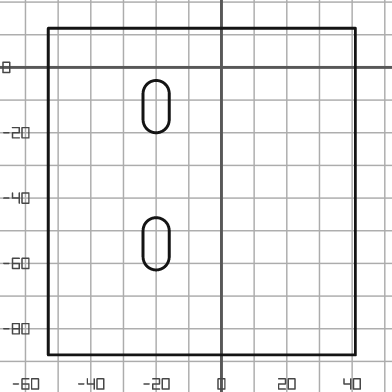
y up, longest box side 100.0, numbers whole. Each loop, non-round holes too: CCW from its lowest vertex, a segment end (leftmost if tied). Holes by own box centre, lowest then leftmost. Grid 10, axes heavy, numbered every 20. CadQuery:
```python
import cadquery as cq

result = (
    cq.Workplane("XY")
    .moveTo(-53.0, -88.0)
    .lineTo(41.0, -88.0)
    .lineTo(41.0, 12.0)
    .lineTo(-53.0, 12.0)
    .close()
    .moveTo(-24.0, -58.0)
    .threePointArc((-20.0, -62.0), (-16.0, -58.0))
    .lineTo(-16.0, -50.0)
    .threePointArc((-20.0, -46.0), (-24.0, -50.0))
    .close()
    .moveTo(-24.0, -16.0)
    .threePointArc((-20.0, -20.0), (-16.0, -16.0))
    .lineTo(-16.0, -8.0)
    .threePointArc((-20.0, -4.0), (-24.0, -8.0))
    .close()
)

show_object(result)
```